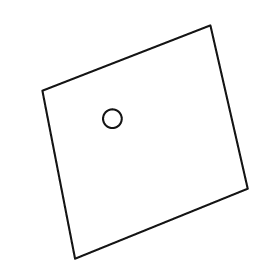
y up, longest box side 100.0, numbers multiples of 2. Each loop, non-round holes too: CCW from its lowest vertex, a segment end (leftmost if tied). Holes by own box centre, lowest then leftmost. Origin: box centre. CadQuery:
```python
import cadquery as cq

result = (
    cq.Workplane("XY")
    .moveTo(-30.0, -50.0)
    .lineTo(44.0, -20.0)
    .lineTo(28.0, 50.0)
    .lineTo(-44.0, 22.0)
    .close()
    .moveTo(-14.0, 10.0)
    .circle(4.0)
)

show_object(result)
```